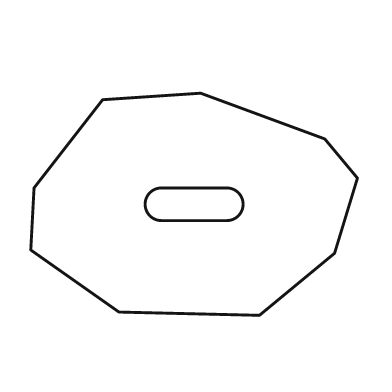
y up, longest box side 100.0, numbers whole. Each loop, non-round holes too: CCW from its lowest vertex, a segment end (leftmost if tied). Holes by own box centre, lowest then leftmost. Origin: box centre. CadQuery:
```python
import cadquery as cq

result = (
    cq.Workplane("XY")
    .moveTo(20.0, -34.0)
    .lineTo(43.0, -15.0)
    .lineTo(50.0, 8.0)
    .lineTo(40.0, 20.0)
    .lineTo(2.0, 34.0)
    .lineTo(-28.0, 32.0)
    .lineTo(-49.0, 5.0)
    .lineTo(-50.0, -14.0)
    .lineTo(-23.0, -33.0)
    .close()
    .moveTo(-10.0, -5.0)
    .lineTo(10.0, -5.0)
    .threePointArc((15.0, 0.0), (10.0, 5.0))
    .lineTo(-10.0, 5.0)
    .threePointArc((-15.0, 0.0), (-10.0, -5.0))
    .close()
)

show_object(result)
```